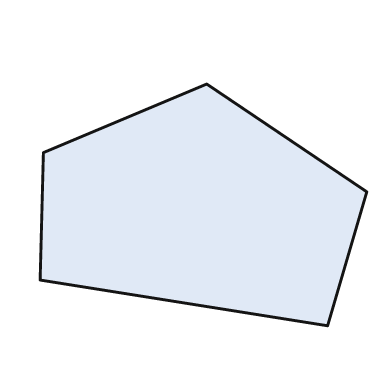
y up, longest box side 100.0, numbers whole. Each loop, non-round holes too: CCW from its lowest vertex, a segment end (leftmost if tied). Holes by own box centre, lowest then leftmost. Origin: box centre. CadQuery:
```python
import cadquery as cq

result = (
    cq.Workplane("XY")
    .moveTo(38.0, -37.0)
    .lineTo(50.0, 4.0)
    .lineTo(1.0, 37.0)
    .lineTo(-49.0, 16.0)
    .lineTo(-50.0, -23.0)
    .close()
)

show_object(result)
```